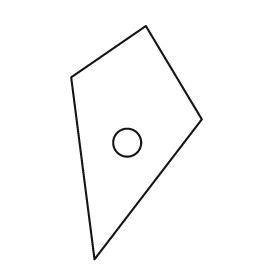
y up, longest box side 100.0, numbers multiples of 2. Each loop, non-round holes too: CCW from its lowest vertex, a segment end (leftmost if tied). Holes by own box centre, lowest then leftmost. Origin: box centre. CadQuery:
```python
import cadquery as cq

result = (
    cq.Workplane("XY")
    .moveTo(-18.0, -50.0)
    .lineTo(28.0, 10.0)
    .lineTo(4.0, 50.0)
    .lineTo(-28.0, 28.0)
    .close()
    .moveTo(-4.0, 0.0)
    .circle(6.0)
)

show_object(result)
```